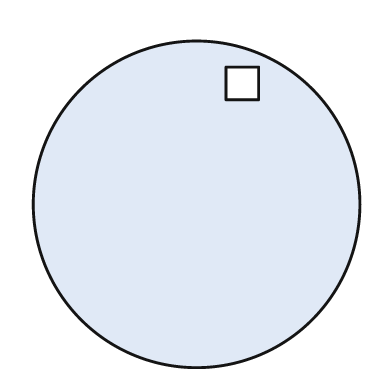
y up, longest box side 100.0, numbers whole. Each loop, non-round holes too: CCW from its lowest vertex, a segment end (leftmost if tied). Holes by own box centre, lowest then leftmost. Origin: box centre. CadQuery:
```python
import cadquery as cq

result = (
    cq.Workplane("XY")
    .moveTo(0.0, 0.0)
    .circle(50.0)
    .moveTo(9.0, 32.0)
    .lineTo(19.0, 32.0)
    .lineTo(19.0, 42.0)
    .lineTo(9.0, 42.0)
    .close()
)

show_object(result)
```